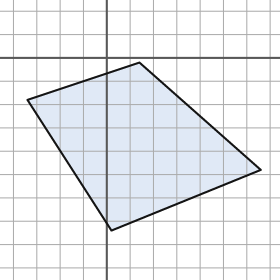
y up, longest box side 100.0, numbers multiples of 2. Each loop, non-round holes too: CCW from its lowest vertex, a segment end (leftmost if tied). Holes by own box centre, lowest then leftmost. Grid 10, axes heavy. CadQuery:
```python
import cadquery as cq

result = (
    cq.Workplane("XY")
    .moveTo(2.0, -74.0)
    .lineTo(66.0, -48.0)
    .lineTo(14.0, -2.0)
    .lineTo(-34.0, -18.0)
    .close()
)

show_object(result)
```